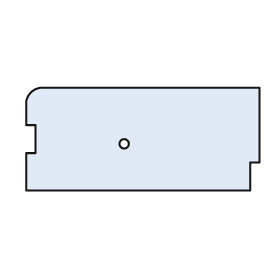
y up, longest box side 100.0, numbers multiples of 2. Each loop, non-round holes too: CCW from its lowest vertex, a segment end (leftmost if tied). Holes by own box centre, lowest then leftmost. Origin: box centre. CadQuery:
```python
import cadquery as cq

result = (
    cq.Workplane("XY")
    .moveTo(-50.0, -22.0)
    .lineTo(46.0, -22.0)
    .lineTo(46.0, -10.0)
    .lineTo(50.0, -10.0)
    .lineTo(50.0, 22.0)
    .lineTo(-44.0, 22.0)
    .threePointArc((-48.0, 20.0), (-50.0, 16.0))
    .lineTo(-50.0, 6.0)
    .lineTo(-46.0, 6.0)
    .lineTo(-46.0, -6.0)
    .lineTo(-50.0, -6.0)
    .close()
    .moveTo(-8.0, -2.0)
    .circle(2.0)
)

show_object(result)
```